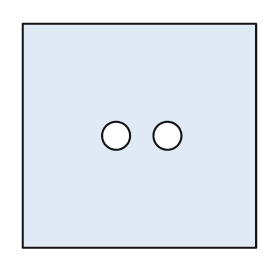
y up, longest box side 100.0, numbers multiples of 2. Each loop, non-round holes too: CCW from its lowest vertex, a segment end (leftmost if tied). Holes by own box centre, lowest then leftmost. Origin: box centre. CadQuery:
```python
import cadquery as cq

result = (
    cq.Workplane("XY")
    .moveTo(-50.0, -48.0)
    .lineTo(50.0, -48.0)
    .lineTo(50.0, 48.0)
    .lineTo(-50.0, 48.0)
    .close()
    .moveTo(-10.0, 0.0)
    .circle(6.0)
    .moveTo(12.0, 0.0)
    .circle(6.0)
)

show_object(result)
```